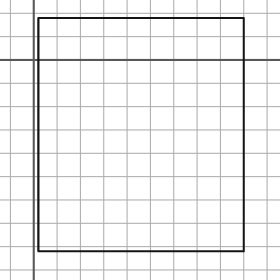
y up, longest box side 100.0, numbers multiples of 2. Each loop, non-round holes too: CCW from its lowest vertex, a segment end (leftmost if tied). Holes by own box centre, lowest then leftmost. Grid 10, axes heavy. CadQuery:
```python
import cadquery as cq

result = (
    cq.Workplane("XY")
    .moveTo(2.0, -82.0)
    .lineTo(90.0, -82.0)
    .lineTo(90.0, 18.0)
    .lineTo(2.0, 18.0)
    .close()
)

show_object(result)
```